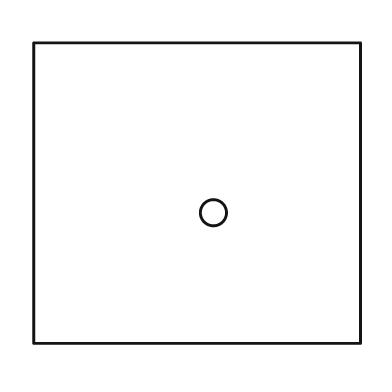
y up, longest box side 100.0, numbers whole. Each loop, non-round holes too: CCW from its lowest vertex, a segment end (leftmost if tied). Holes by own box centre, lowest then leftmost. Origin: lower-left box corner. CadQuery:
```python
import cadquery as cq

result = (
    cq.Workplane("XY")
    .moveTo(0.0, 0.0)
    .lineTo(100.0, 0.0)
    .lineTo(100.0, 92.0)
    .lineTo(0.0, 92.0)
    .close()
    .moveTo(55.0, 40.0)
    .circle(4.0)
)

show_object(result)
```